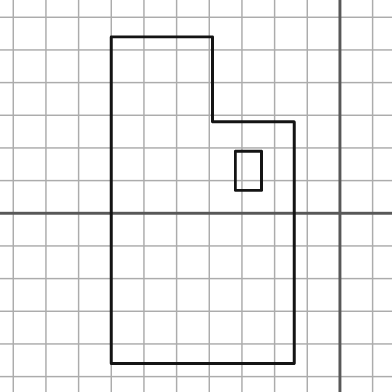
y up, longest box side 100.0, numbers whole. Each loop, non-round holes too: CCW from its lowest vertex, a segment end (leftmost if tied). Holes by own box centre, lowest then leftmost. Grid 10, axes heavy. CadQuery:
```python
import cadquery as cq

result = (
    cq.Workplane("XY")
    .moveTo(-70.0, -46.0)
    .lineTo(-14.0, -46.0)
    .lineTo(-14.0, 28.0)
    .lineTo(-39.0, 28.0)
    .lineTo(-39.0, 54.0)
    .lineTo(-70.0, 54.0)
    .close()
    .moveTo(-32.0, 7.0)
    .lineTo(-24.0, 7.0)
    .lineTo(-24.0, 19.0)
    .lineTo(-32.0, 19.0)
    .close()
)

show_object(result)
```